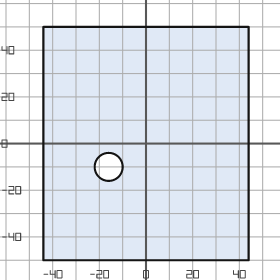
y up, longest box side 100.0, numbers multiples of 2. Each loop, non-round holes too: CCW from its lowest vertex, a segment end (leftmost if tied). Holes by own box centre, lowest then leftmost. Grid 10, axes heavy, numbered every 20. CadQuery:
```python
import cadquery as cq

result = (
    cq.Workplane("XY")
    .moveTo(-44.0, -50.0)
    .lineTo(44.0, -50.0)
    .lineTo(44.0, 50.0)
    .lineTo(-44.0, 50.0)
    .close()
    .moveTo(-16.0, -10.0)
    .circle(6.0)
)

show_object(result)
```